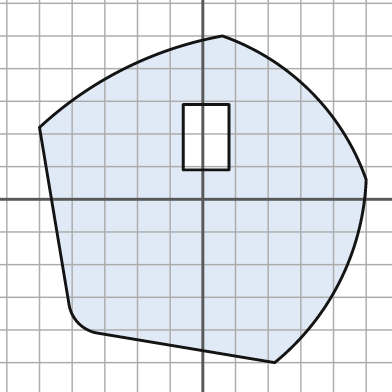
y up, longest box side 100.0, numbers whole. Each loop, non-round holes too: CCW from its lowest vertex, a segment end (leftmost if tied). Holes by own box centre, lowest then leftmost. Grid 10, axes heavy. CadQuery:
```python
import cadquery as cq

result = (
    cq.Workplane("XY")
    .moveTo(22.0, -50.0)
    .threePointArc((42.0, -25.0), (50.0, 6.0))
    .threePointArc((33.0, 33.0), (6.0, 50.0))
    .threePointArc((-24.0, 40.0), (-50.0, 22.0))
    .lineTo(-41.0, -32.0)
    .threePointArc((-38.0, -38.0), (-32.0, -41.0))
    .close()
    .moveTo(-6.0, 9.0)
    .lineTo(8.0, 9.0)
    .lineTo(8.0, 29.0)
    .lineTo(-6.0, 29.0)
    .close()
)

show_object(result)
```